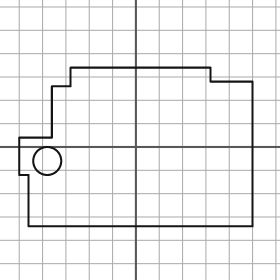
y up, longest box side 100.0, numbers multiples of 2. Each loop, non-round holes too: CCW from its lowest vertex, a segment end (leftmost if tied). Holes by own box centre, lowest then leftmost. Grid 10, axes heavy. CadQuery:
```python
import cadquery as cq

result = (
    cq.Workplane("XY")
    .moveTo(-46.0, -34.0)
    .lineTo(50.0, -34.0)
    .lineTo(50.0, 28.0)
    .lineTo(32.0, 28.0)
    .lineTo(32.0, 34.0)
    .lineTo(-28.0, 34.0)
    .lineTo(-28.0, 26.0)
    .lineTo(-36.0, 26.0)
    .lineTo(-36.0, 4.0)
    .lineTo(-50.0, 4.0)
    .lineTo(-50.0, -12.0)
    .lineTo(-46.0, -12.0)
    .close()
    .moveTo(-38.0, -6.0)
    .circle(6.0)
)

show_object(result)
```